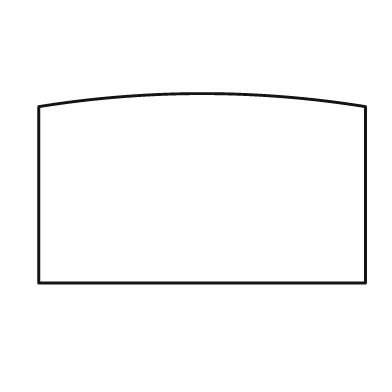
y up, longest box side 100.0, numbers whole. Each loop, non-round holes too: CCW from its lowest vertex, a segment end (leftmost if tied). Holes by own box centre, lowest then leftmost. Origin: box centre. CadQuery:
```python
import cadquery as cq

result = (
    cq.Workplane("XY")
    .moveTo(-50.0, -29.0)
    .lineTo(50.0, -29.0)
    .lineTo(50.0, 25.0)
    .threePointArc((0.0, 29.0), (-50.0, 25.0))
    .close()
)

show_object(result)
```